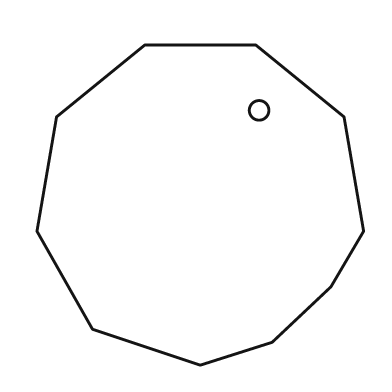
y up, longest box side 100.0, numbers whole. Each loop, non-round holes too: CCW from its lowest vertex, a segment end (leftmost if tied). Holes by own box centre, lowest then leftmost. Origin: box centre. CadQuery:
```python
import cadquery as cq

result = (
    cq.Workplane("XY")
    .moveTo(0.0, -49.0)
    .lineTo(22.0, -42.0)
    .lineTo(40.0, -25.0)
    .lineTo(50.0, -8.0)
    .lineTo(44.0, 27.0)
    .lineTo(17.0, 49.0)
    .lineTo(-17.0, 49.0)
    .lineTo(-44.0, 27.0)
    .lineTo(-50.0, -8.0)
    .lineTo(-33.0, -38.0)
    .close()
    .moveTo(18.0, 29.0)
    .circle(3.0)
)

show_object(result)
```